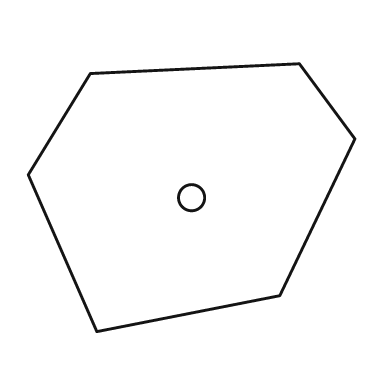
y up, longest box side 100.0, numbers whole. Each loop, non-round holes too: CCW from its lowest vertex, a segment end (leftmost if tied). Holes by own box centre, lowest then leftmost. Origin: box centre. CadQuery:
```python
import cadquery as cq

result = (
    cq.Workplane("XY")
    .moveTo(-29.0, -41.0)
    .lineTo(27.0, -30.0)
    .lineTo(50.0, 18.0)
    .lineTo(33.0, 41.0)
    .lineTo(-31.0, 38.0)
    .lineTo(-50.0, 7.0)
    .close()
    .moveTo(0.0, 0.0)
    .circle(4.0)
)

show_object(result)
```